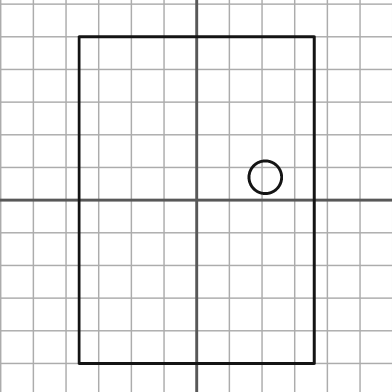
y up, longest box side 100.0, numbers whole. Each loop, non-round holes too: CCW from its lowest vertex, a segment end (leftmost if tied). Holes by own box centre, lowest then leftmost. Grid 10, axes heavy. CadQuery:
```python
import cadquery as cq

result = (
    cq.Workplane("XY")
    .moveTo(-36.0, -50.0)
    .lineTo(36.0, -50.0)
    .lineTo(36.0, 50.0)
    .lineTo(-36.0, 50.0)
    .close()
    .moveTo(21.0, 7.0)
    .circle(5.0)
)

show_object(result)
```